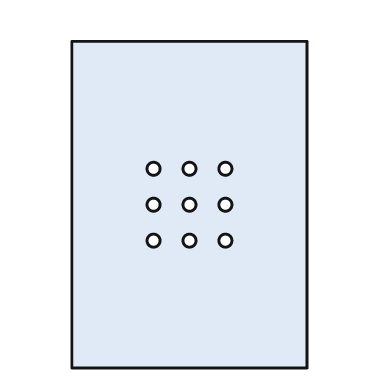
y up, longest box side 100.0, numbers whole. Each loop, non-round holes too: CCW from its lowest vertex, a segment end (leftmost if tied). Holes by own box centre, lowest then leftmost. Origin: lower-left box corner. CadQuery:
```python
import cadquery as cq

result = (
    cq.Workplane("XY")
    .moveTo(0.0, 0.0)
    .lineTo(72.0, 0.0)
    .lineTo(72.0, 100.0)
    .lineTo(0.0, 100.0)
    .close()
    .moveTo(25.0, 39.0)
    .circle(2.0)
    .moveTo(36.0, 39.0)
    .circle(2.0)
    .moveTo(47.0, 39.0)
    .circle(2.0)
    .moveTo(25.0, 50.0)
    .circle(2.0)
    .moveTo(36.0, 50.0)
    .circle(2.0)
    .moveTo(47.0, 50.0)
    .circle(2.0)
    .moveTo(25.0, 61.0)
    .circle(2.0)
    .moveTo(36.0, 61.0)
    .circle(2.0)
    .moveTo(47.0, 61.0)
    .circle(2.0)
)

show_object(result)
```